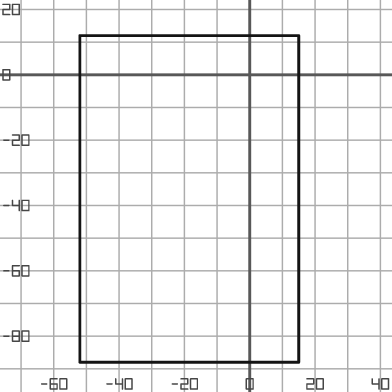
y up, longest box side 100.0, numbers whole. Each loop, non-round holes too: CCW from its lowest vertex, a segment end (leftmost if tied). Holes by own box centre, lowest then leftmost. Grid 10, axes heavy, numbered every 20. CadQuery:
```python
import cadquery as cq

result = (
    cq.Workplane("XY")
    .moveTo(-52.0, -88.0)
    .lineTo(15.0, -88.0)
    .lineTo(15.0, 12.0)
    .lineTo(-52.0, 12.0)
    .close()
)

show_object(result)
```